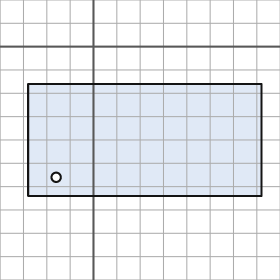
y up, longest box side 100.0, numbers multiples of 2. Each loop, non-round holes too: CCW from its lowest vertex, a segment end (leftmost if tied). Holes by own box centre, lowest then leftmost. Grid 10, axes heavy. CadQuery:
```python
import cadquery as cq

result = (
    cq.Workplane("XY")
    .moveTo(-28.0, -64.0)
    .lineTo(72.0, -64.0)
    .lineTo(72.0, -16.0)
    .lineTo(-28.0, -16.0)
    .close()
    .moveTo(-16.0, -56.0)
    .circle(2.0)
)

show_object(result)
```